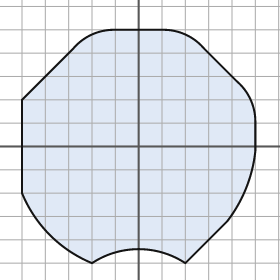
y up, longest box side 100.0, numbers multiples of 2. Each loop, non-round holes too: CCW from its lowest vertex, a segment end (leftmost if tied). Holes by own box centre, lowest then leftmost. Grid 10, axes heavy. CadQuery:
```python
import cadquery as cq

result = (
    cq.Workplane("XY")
    .moveTo(-20.0, -50.0)
    .threePointArc((0.0, -44.0), (20.0, -50.0))
    .lineTo(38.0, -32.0)
    .threePointArc((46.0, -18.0), (50.0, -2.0))
    .lineTo(50.0, 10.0)
    .threePointArc((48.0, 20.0), (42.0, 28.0))
    .lineTo(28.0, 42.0)
    .threePointArc((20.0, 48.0), (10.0, 50.0))
    .lineTo(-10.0, 50.0)
    .threePointArc((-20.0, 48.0), (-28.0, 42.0))
    .lineTo(-50.0, 20.0)
    .lineTo(-50.0, -20.0)
    .threePointArc((-38.0, -38.0), (-20.0, -50.0))
    .close()
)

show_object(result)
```